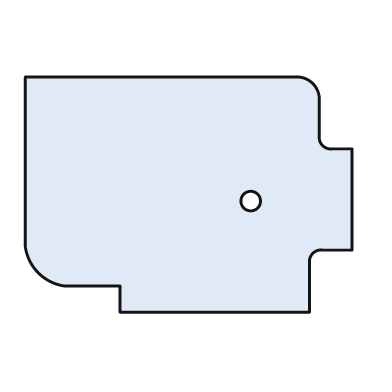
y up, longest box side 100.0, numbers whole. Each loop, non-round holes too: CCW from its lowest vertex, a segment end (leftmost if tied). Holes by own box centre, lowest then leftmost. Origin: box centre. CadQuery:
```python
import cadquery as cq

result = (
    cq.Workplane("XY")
    .moveTo(-21.0, -36.0)
    .lineTo(37.0, -36.0)
    .lineTo(37.0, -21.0)
    .threePointArc((38.0, -18.0), (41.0, -17.0))
    .lineTo(50.0, -17.0)
    .lineTo(50.0, 14.0)
    .lineTo(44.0, 14.0)
    .threePointArc((41.0, 15.0), (40.0, 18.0))
    .lineTo(40.0, 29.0)
    .threePointArc((38.0, 34.0), (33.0, 36.0))
    .lineTo(-50.0, 36.0)
    .lineTo(-50.0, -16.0)
    .threePointArc((-46.0, -24.0), (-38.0, -28.0))
    .lineTo(-21.0, -28.0)
    .close()
    .moveTo(19.0, -2.0)
    .circle(3.0)
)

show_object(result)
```